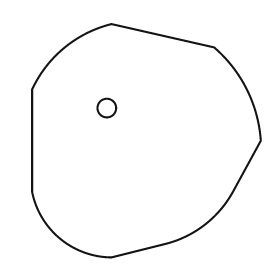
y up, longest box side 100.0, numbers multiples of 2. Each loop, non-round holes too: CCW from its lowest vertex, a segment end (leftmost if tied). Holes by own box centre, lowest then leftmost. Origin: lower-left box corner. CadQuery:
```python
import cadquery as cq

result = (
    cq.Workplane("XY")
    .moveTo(34.0, 0.0)
    .lineTo(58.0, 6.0)
    .threePointArc((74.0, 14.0), (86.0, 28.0))
    .lineTo(98.0, 50.0)
    .threePointArc((92.0, 72.0), (78.0, 90.0))
    .lineTo(34.0, 100.0)
    .threePointArc((14.0, 90.0), (0.0, 72.0))
    .lineTo(0.0, 28.0)
    .threePointArc((12.0, 8.0), (34.0, 0.0))
    .close()
    .moveTo(32.0, 64.0)
    .circle(4.0)
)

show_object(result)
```